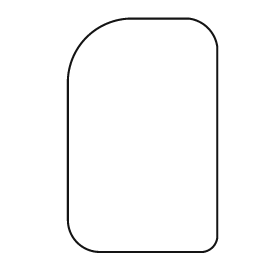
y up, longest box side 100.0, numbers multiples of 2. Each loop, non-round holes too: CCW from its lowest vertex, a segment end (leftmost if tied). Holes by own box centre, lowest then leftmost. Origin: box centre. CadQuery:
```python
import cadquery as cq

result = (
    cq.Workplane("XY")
    .moveTo(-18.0, -50.0)
    .lineTo(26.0, -50.0)
    .threePointArc((30.0, -48.0), (32.0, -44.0))
    .lineTo(32.0, 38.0)
    .threePointArc((28.0, 46.0), (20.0, 50.0))
    .lineTo(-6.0, 50.0)
    .threePointArc((-24.0, 42.0), (-32.0, 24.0))
    .lineTo(-32.0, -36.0)
    .threePointArc((-28.0, -46.0), (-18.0, -50.0))
    .close()
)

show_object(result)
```